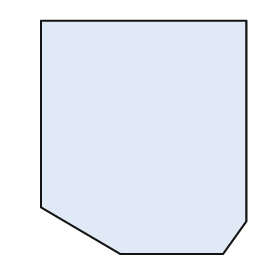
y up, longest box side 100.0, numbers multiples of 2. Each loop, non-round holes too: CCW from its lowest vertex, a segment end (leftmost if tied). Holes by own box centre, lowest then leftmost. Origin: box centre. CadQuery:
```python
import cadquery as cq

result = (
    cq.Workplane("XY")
    .moveTo(-10.0, -50.0)
    .lineTo(34.0, -50.0)
    .lineTo(44.0, -36.0)
    .lineTo(44.0, 50.0)
    .lineTo(-44.0, 50.0)
    .lineTo(-44.0, -30.0)
    .close()
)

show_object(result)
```